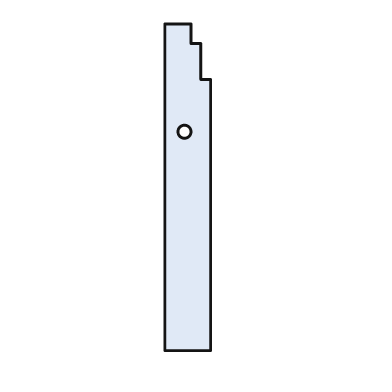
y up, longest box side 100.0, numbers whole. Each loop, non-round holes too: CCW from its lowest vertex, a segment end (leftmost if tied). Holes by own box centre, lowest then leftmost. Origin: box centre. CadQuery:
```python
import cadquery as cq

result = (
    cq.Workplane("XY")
    .moveTo(-7.0, -50.0)
    .lineTo(7.0, -50.0)
    .lineTo(7.0, 33.0)
    .lineTo(4.0, 33.0)
    .lineTo(4.0, 44.0)
    .lineTo(1.0, 44.0)
    .lineTo(1.0, 50.0)
    .lineTo(-7.0, 50.0)
    .close()
    .moveTo(-1.0, 17.0)
    .circle(2.0)
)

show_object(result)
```